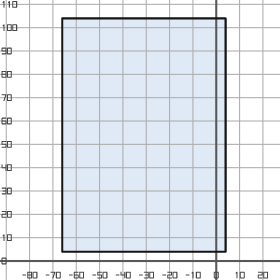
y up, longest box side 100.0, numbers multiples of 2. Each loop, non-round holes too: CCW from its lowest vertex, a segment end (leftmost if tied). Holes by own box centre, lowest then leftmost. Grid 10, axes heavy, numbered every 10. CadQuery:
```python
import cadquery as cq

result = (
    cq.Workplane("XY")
    .moveTo(-66.0, 4.0)
    .lineTo(4.0, 4.0)
    .lineTo(4.0, 104.0)
    .lineTo(-66.0, 104.0)
    .close()
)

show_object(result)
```